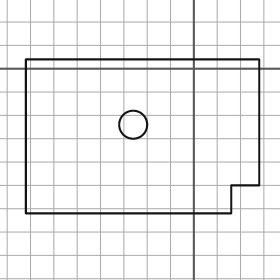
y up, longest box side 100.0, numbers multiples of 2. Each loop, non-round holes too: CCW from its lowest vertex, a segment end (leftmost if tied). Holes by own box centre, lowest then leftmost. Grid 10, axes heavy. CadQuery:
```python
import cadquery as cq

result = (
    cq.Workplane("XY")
    .moveTo(-72.0, -62.0)
    .lineTo(16.0, -62.0)
    .lineTo(16.0, -50.0)
    .lineTo(28.0, -50.0)
    .lineTo(28.0, 4.0)
    .lineTo(-72.0, 4.0)
    .close()
    .moveTo(-26.0, -24.0)
    .circle(6.0)
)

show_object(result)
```